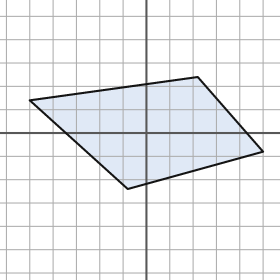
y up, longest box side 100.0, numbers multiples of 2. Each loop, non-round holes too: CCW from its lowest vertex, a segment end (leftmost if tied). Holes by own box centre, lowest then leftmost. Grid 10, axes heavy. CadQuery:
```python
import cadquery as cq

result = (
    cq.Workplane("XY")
    .moveTo(-8.0, -24.0)
    .lineTo(50.0, -8.0)
    .lineTo(22.0, 24.0)
    .lineTo(-50.0, 14.0)
    .close()
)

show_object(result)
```